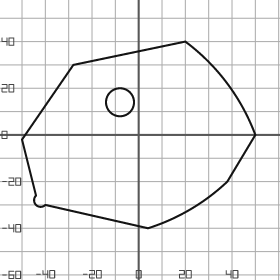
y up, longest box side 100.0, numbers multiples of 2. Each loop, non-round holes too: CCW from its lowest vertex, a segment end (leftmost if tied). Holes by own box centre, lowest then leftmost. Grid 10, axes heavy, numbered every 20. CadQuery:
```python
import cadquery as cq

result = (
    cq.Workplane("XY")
    .moveTo(4.0, -40.0)
    .threePointArc((22.0, -32.0), (38.0, -20.0))
    .lineTo(50.0, 0.0)
    .threePointArc((38.0, 22.0), (20.0, 40.0))
    .lineTo(-28.0, 30.0)
    .lineTo(-50.0, -2.0)
    .lineTo(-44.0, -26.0)
    .threePointArc((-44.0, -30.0), (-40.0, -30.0))
    .close()
    .moveTo(-8.0, 14.0)
    .circle(6.0)
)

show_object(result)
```